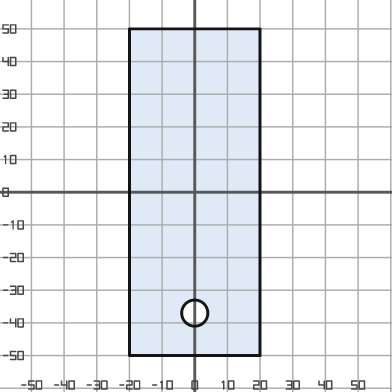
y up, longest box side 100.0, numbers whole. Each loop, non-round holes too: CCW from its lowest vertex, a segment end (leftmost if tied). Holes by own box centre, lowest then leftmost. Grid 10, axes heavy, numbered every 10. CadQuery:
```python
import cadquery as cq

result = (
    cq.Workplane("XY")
    .moveTo(-20.0, -50.0)
    .lineTo(20.0, -50.0)
    .lineTo(20.0, 50.0)
    .lineTo(-20.0, 50.0)
    .close()
    .moveTo(0.0, -37.0)
    .circle(4.0)
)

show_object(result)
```